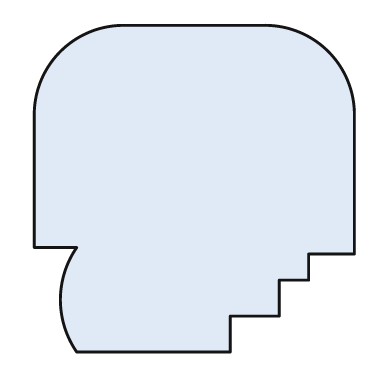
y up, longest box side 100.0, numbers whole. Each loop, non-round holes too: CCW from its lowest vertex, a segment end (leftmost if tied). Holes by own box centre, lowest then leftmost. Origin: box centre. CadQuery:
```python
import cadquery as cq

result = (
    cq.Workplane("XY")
    .moveTo(-36.0, -50.0)
    .lineTo(11.0, -50.0)
    .lineTo(11.0, -39.0)
    .lineTo(26.0, -39.0)
    .lineTo(26.0, -28.0)
    .lineTo(35.0, -28.0)
    .lineTo(35.0, -20.0)
    .lineTo(49.0, -20.0)
    .lineTo(49.0, 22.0)
    .threePointArc((41.0, 42.0), (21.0, 50.0))
    .lineTo(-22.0, 50.0)
    .threePointArc((-41.0, 42.0), (-49.0, 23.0))
    .lineTo(-49.0, -18.0)
    .lineTo(-36.0, -18.0)
    .threePointArc((-41.0, -34.0), (-36.0, -50.0))
    .close()
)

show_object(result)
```